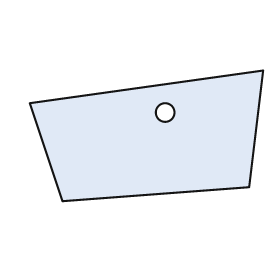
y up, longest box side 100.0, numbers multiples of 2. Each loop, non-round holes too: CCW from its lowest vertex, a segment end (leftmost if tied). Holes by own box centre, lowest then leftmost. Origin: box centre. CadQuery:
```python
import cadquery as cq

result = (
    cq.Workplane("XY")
    .moveTo(-36.0, -28.0)
    .lineTo(44.0, -22.0)
    .lineTo(50.0, 28.0)
    .lineTo(-50.0, 14.0)
    .close()
    .moveTo(8.0, 10.0)
    .circle(4.0)
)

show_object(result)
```